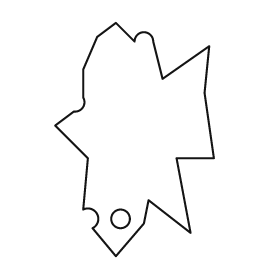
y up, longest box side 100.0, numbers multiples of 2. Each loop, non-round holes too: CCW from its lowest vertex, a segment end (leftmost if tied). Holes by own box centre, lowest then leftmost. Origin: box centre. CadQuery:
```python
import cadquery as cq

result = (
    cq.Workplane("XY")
    .moveTo(-8.0, -50.0)
    .lineTo(4.0, -36.0)
    .lineTo(6.0, -26.0)
    .lineTo(24.0, -40.0)
    .lineTo(18.0, -8.0)
    .lineTo(34.0, -8.0)
    .lineTo(30.0, 20.0)
    .lineTo(32.0, 40.0)
    .lineTo(12.0, 26.0)
    .lineTo(8.0, 42.0)
    .threePointArc((4.0, 46.0), (0.0, 42.0))
    .lineTo(-8.0, 50.0)
    .lineTo(-16.0, 44.0)
    .lineTo(-22.0, 30.0)
    .lineTo(-22.0, 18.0)
    .threePointArc((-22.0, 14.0), (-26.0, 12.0))
    .lineTo(-34.0, 6.0)
    .lineTo(-20.0, -8.0)
    .lineTo(-22.0, -30.0)
    .threePointArc((-16.0, -32.0), (-18.0, -38.0))
    .close()
    .moveTo(-6.0, -34.0)
    .circle(4.0)
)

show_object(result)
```